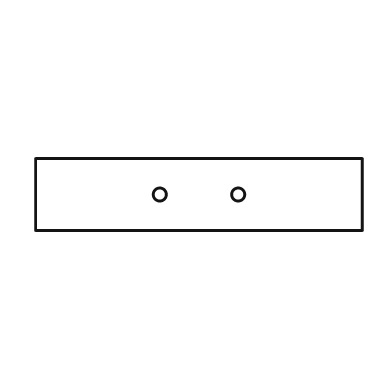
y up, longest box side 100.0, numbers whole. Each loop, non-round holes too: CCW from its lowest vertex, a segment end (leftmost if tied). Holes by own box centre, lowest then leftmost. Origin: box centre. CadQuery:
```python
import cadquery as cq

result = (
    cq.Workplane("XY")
    .moveTo(-50.0, -11.0)
    .lineTo(50.0, -11.0)
    .lineTo(50.0, 11.0)
    .lineTo(-50.0, 11.0)
    .close()
    .moveTo(-12.0, 0.0)
    .circle(2.0)
    .moveTo(12.0, 0.0)
    .circle(2.0)
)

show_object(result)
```